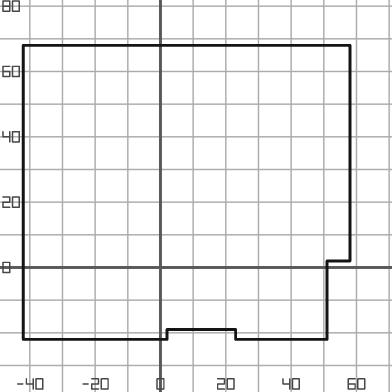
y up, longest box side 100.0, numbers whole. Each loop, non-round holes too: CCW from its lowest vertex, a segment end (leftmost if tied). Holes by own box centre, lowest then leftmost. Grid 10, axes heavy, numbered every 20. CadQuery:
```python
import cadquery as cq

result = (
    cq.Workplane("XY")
    .moveTo(-42.0, -22.0)
    .lineTo(2.0, -22.0)
    .lineTo(2.0, -19.0)
    .lineTo(23.0, -19.0)
    .lineTo(23.0, -22.0)
    .lineTo(51.0, -22.0)
    .lineTo(51.0, 2.0)
    .lineTo(58.0, 2.0)
    .lineTo(58.0, 68.0)
    .lineTo(-42.0, 68.0)
    .close()
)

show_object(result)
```